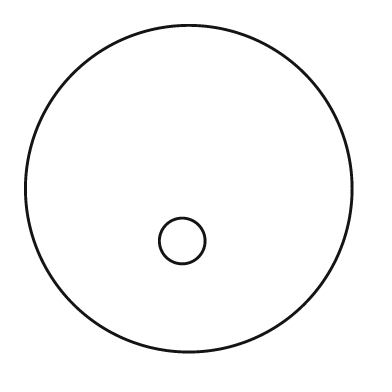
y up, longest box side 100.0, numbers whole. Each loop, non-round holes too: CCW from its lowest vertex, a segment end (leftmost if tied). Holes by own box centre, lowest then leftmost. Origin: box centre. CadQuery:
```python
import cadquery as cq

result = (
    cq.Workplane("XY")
    .moveTo(0.0, 0.0)
    .circle(50.0)
    .moveTo(-2.0, -16.0)
    .circle(7.0)
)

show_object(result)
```